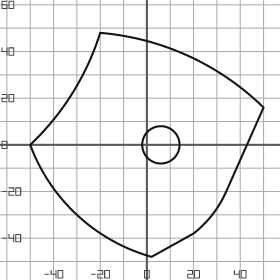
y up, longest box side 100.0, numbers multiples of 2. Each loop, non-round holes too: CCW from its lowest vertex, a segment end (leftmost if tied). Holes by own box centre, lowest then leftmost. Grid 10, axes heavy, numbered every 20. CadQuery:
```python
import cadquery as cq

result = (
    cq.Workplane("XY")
    .moveTo(2.0, -48.0)
    .lineTo(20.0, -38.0)
    .threePointArc((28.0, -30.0), (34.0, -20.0))
    .lineTo(50.0, 16.0)
    .threePointArc((18.0, 38.0), (-20.0, 48.0))
    .threePointArc((-32.0, 22.0), (-50.0, 0.0))
    .threePointArc((-30.0, -30.0), (2.0, -48.0))
    .close()
    .moveTo(6.0, 0.0)
    .circle(8.0)
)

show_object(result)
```